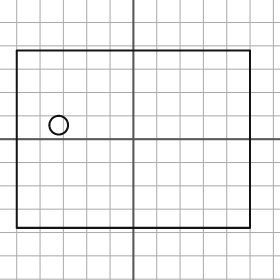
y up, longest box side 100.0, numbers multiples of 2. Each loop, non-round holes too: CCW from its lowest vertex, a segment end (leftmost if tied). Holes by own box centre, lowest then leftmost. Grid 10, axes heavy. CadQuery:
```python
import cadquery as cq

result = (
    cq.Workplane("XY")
    .moveTo(-50.0, -38.0)
    .lineTo(50.0, -38.0)
    .lineTo(50.0, 38.0)
    .lineTo(-50.0, 38.0)
    .close()
    .moveTo(-32.0, 6.0)
    .circle(4.0)
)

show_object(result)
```